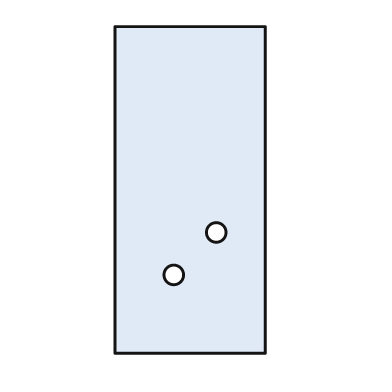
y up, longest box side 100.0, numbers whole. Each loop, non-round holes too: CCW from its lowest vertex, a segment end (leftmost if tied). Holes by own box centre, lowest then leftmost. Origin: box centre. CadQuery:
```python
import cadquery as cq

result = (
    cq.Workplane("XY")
    .moveTo(-23.0, -50.0)
    .lineTo(23.0, -50.0)
    .lineTo(23.0, 50.0)
    .lineTo(-23.0, 50.0)
    .close()
    .moveTo(-5.0, -26.0)
    .circle(3.0)
    .moveTo(8.0, -13.0)
    .circle(3.0)
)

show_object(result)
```